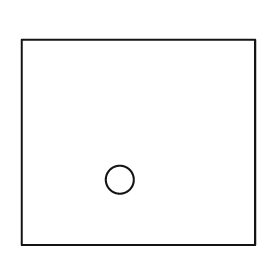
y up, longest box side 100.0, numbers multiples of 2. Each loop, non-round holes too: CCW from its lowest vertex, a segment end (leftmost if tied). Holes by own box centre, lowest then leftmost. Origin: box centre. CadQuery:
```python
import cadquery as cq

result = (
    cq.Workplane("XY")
    .moveTo(-50.0, -44.0)
    .lineTo(50.0, -44.0)
    .lineTo(50.0, 44.0)
    .lineTo(-50.0, 44.0)
    .close()
    .moveTo(-8.0, -16.0)
    .circle(6.0)
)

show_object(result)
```